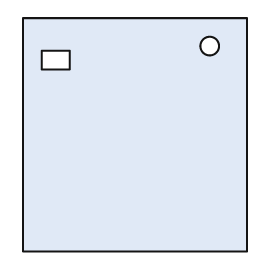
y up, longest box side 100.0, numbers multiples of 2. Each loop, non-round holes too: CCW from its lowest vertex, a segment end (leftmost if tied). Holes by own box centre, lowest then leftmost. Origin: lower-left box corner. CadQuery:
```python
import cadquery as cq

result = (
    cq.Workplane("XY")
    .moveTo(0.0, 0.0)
    .lineTo(96.0, 0.0)
    .lineTo(96.0, 100.0)
    .lineTo(0.0, 100.0)
    .close()
    .moveTo(8.0, 78.0)
    .lineTo(20.0, 78.0)
    .lineTo(20.0, 86.0)
    .lineTo(8.0, 86.0)
    .close()
    .moveTo(80.0, 88.0)
    .circle(4.0)
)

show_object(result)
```